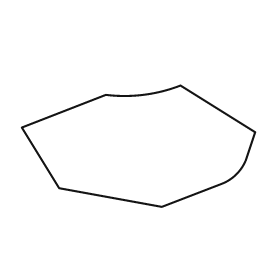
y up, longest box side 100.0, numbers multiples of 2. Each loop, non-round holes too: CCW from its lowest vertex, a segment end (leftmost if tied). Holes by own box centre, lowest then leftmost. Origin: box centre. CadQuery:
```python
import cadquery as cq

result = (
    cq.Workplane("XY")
    .moveTo(10.0, -26.0)
    .lineTo(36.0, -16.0)
    .threePointArc((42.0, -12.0), (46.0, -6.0))
    .lineTo(50.0, 6.0)
    .lineTo(18.0, 26.0)
    .threePointArc((2.0, 22.0), (-14.0, 22.0))
    .lineTo(-50.0, 8.0)
    .lineTo(-34.0, -18.0)
    .close()
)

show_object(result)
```